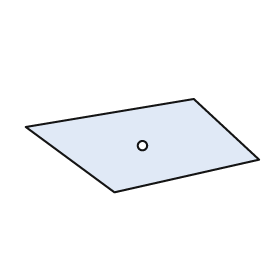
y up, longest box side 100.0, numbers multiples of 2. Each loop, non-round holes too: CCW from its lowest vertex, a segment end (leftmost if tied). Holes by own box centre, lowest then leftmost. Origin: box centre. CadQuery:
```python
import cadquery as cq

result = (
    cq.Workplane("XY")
    .moveTo(-12.0, -20.0)
    .lineTo(50.0, -6.0)
    .lineTo(22.0, 20.0)
    .lineTo(-50.0, 8.0)
    .close()
    .moveTo(0.0, 0.0)
    .circle(2.0)
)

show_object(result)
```